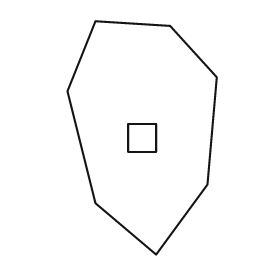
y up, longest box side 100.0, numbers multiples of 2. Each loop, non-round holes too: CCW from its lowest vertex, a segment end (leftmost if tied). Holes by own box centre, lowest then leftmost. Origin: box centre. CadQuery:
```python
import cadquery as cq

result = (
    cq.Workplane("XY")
    .moveTo(6.0, -50.0)
    .lineTo(28.0, -20.0)
    .lineTo(32.0, 26.0)
    .lineTo(12.0, 48.0)
    .lineTo(-20.0, 50.0)
    .lineTo(-32.0, 20.0)
    .lineTo(-20.0, -28.0)
    .close()
    .moveTo(-6.0, -6.0)
    .lineTo(6.0, -6.0)
    .lineTo(6.0, 6.0)
    .lineTo(-6.0, 6.0)
    .close()
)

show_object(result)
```